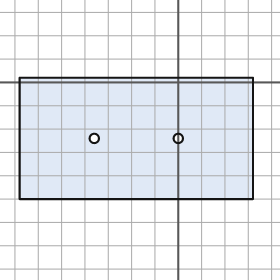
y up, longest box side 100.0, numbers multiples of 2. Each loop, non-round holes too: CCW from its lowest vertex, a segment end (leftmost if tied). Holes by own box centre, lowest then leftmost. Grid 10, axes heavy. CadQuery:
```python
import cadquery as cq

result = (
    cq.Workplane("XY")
    .moveTo(-68.0, -50.0)
    .lineTo(32.0, -50.0)
    .lineTo(32.0, 2.0)
    .lineTo(-68.0, 2.0)
    .close()
    .moveTo(-36.0, -24.0)
    .circle(2.0)
    .moveTo(0.0, -24.0)
    .circle(2.0)
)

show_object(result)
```